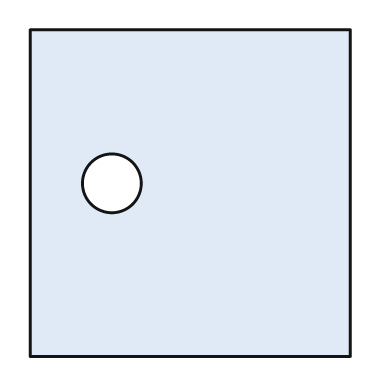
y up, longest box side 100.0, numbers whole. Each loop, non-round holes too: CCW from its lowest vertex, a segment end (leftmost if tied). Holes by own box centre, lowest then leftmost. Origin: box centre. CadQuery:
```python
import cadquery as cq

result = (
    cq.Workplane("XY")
    .moveTo(-49.0, -50.0)
    .lineTo(49.0, -50.0)
    .lineTo(49.0, 50.0)
    .lineTo(-49.0, 50.0)
    .close()
    .moveTo(-24.0, 3.0)
    .circle(9.0)
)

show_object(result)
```